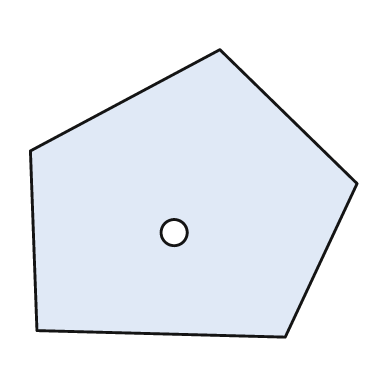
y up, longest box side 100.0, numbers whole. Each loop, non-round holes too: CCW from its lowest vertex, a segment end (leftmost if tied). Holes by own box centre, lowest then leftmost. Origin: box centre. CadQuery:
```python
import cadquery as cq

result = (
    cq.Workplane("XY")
    .moveTo(28.0, -44.0)
    .lineTo(50.0, 3.0)
    .lineTo(8.0, 44.0)
    .lineTo(-50.0, 13.0)
    .lineTo(-48.0, -42.0)
    .close()
    .moveTo(-6.0, -12.0)
    .circle(4.0)
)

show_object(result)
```